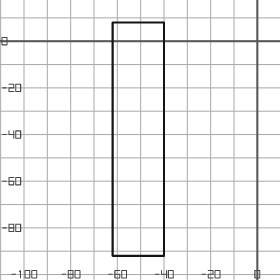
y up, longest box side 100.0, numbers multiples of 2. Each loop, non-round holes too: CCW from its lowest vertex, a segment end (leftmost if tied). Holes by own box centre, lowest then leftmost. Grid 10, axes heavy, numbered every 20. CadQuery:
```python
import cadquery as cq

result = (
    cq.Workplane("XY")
    .moveTo(-62.0, -92.0)
    .lineTo(-40.0, -92.0)
    .lineTo(-40.0, 8.0)
    .lineTo(-62.0, 8.0)
    .close()
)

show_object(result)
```